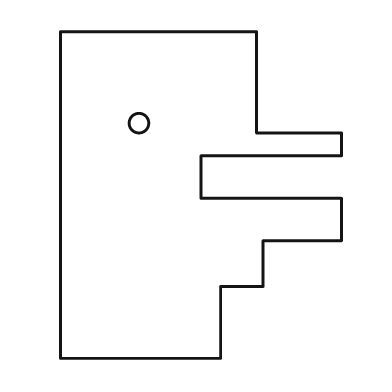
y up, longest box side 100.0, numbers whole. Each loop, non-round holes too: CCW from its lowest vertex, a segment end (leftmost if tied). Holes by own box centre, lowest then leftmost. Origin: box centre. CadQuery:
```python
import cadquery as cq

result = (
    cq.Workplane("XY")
    .moveTo(-43.0, -50.0)
    .lineTo(6.0, -50.0)
    .lineTo(6.0, -28.0)
    .lineTo(19.0, -28.0)
    .lineTo(19.0, -14.0)
    .lineTo(43.0, -14.0)
    .lineTo(43.0, -1.0)
    .lineTo(0.0, -1.0)
    .lineTo(0.0, 12.0)
    .lineTo(43.0, 12.0)
    .lineTo(43.0, 19.0)
    .lineTo(17.0, 19.0)
    .lineTo(17.0, 50.0)
    .lineTo(-43.0, 50.0)
    .close()
    .moveTo(-19.0, 22.0)
    .circle(3.0)
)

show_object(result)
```